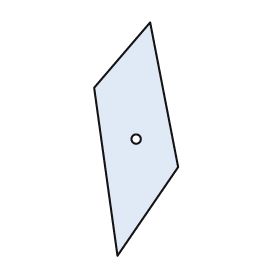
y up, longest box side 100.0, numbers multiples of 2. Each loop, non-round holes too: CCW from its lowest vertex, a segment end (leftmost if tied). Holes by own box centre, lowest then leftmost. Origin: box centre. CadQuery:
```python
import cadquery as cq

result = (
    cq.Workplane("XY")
    .moveTo(-8.0, -50.0)
    .lineTo(18.0, -12.0)
    .lineTo(6.0, 50.0)
    .lineTo(-18.0, 22.0)
    .close()
    .moveTo(0.0, 0.0)
    .circle(2.0)
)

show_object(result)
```